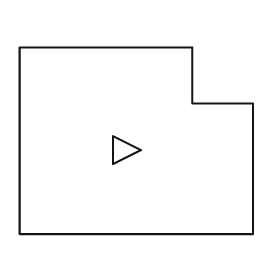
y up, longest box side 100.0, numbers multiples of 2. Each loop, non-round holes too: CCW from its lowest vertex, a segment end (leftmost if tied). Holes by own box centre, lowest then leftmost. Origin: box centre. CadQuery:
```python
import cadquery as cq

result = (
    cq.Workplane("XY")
    .moveTo(-50.0, -40.0)
    .lineTo(50.0, -40.0)
    .lineTo(50.0, 16.0)
    .lineTo(24.0, 16.0)
    .lineTo(24.0, 40.0)
    .lineTo(-50.0, 40.0)
    .close()
    .moveTo(-10.0, -10.0)
    .lineTo(2.0, -4.0)
    .lineTo(-10.0, 2.0)
    .close()
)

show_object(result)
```